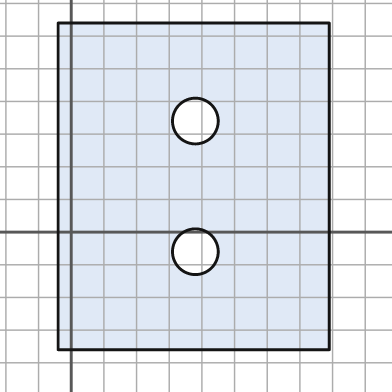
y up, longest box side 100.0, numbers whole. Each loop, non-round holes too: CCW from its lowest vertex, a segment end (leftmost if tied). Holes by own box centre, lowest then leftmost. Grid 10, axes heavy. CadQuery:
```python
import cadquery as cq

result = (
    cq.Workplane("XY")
    .moveTo(-4.0, -36.0)
    .lineTo(79.0, -36.0)
    .lineTo(79.0, 64.0)
    .lineTo(-4.0, 64.0)
    .close()
    .moveTo(38.0, -6.0)
    .circle(7.0)
    .moveTo(38.0, 34.0)
    .circle(7.0)
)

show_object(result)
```